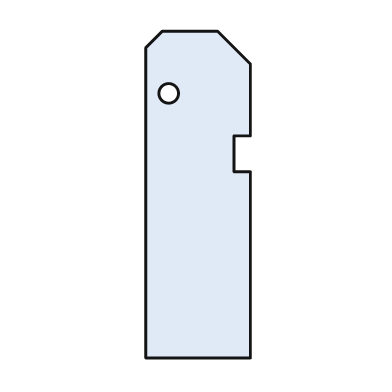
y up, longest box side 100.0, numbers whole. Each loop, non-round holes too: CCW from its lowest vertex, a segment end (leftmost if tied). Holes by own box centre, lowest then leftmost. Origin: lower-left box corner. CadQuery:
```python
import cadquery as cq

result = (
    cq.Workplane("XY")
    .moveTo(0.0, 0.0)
    .lineTo(32.0, 0.0)
    .lineTo(32.0, 57.0)
    .lineTo(27.0, 57.0)
    .lineTo(27.0, 68.0)
    .lineTo(32.0, 68.0)
    .lineTo(32.0, 90.0)
    .lineTo(22.0, 100.0)
    .lineTo(5.0, 100.0)
    .lineTo(0.0, 95.0)
    .close()
    .moveTo(7.0, 81.0)
    .circle(3.0)
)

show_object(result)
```